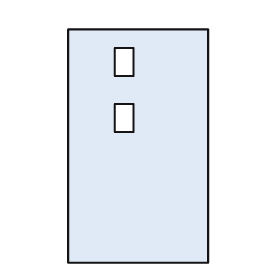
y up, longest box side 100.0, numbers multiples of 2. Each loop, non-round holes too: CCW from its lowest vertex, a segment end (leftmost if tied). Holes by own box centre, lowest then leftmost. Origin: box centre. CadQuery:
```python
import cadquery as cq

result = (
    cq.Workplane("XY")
    .moveTo(-30.0, -50.0)
    .lineTo(30.0, -50.0)
    .lineTo(30.0, 50.0)
    .lineTo(-30.0, 50.0)
    .close()
    .moveTo(-10.0, 6.0)
    .lineTo(-2.0, 6.0)
    .lineTo(-2.0, 18.0)
    .lineTo(-10.0, 18.0)
    .close()
    .moveTo(-10.0, 30.0)
    .lineTo(-2.0, 30.0)
    .lineTo(-2.0, 42.0)
    .lineTo(-10.0, 42.0)
    .close()
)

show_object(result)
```